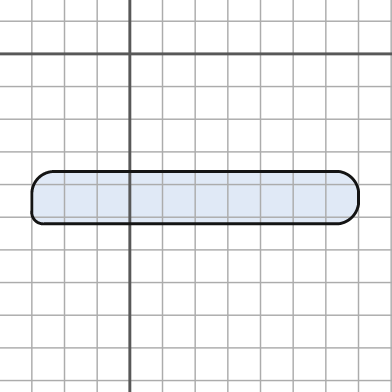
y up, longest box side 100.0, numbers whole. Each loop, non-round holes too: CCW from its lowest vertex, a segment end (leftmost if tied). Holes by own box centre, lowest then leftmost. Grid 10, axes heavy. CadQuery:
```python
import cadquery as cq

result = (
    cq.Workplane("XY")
    .moveTo(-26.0, -52.0)
    .lineTo(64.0, -52.0)
    .threePointArc((68.0, -50.0), (70.0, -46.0))
    .lineTo(70.0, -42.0)
    .threePointArc((68.0, -38.0), (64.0, -36.0))
    .lineTo(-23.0, -36.0)
    .threePointArc((-28.0, -38.0), (-30.0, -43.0))
    .lineTo(-30.0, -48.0)
    .threePointArc((-29.0, -51.0), (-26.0, -52.0))
    .close()
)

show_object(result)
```